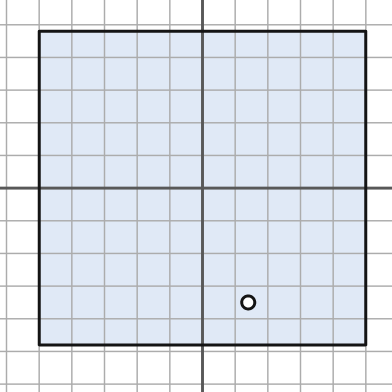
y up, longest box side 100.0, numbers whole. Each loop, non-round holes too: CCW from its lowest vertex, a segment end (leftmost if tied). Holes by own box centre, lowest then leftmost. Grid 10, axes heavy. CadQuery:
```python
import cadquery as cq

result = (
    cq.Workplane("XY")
    .moveTo(-50.0, -48.0)
    .lineTo(50.0, -48.0)
    .lineTo(50.0, 48.0)
    .lineTo(-50.0, 48.0)
    .close()
    .moveTo(14.0, -35.0)
    .circle(2.0)
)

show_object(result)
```